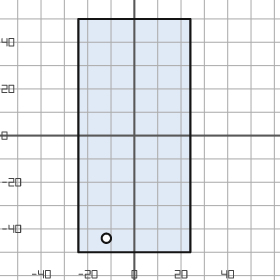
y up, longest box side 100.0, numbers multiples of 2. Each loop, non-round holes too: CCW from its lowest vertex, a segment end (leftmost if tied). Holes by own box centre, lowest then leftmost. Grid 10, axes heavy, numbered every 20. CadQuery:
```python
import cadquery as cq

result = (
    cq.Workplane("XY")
    .moveTo(-24.0, -50.0)
    .lineTo(24.0, -50.0)
    .lineTo(24.0, 50.0)
    .lineTo(-24.0, 50.0)
    .close()
    .moveTo(-12.0, -44.0)
    .circle(2.0)
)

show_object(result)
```